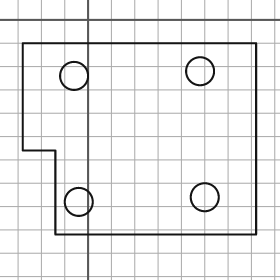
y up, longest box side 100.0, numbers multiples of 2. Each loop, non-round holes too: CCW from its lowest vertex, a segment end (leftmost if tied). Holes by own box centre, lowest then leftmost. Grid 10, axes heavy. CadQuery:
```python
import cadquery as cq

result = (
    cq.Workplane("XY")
    .moveTo(-14.0, -92.0)
    .lineTo(72.0, -92.0)
    .lineTo(72.0, -10.0)
    .lineTo(-28.0, -10.0)
    .lineTo(-28.0, -56.0)
    .lineTo(-14.0, -56.0)
    .close()
    .moveTo(-4.0, -78.0)
    .circle(6.0)
    .moveTo(50.0, -76.0)
    .circle(6.0)
    .moveTo(-6.0, -24.0)
    .circle(6.0)
    .moveTo(48.0, -22.0)
    .circle(6.0)
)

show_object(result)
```